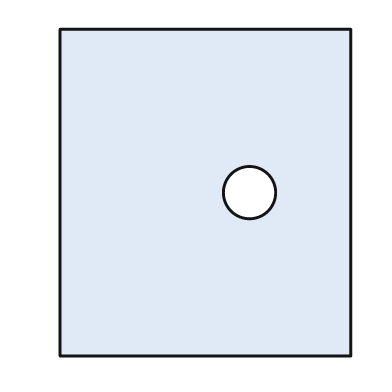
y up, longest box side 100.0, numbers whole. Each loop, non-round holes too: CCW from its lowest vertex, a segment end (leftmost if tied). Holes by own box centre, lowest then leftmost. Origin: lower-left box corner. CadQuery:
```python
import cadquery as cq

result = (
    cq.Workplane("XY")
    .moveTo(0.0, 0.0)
    .lineTo(89.0, 0.0)
    .lineTo(89.0, 100.0)
    .lineTo(0.0, 100.0)
    .close()
    .moveTo(58.0, 50.0)
    .circle(8.0)
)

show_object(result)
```